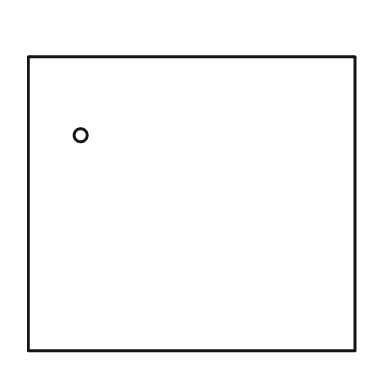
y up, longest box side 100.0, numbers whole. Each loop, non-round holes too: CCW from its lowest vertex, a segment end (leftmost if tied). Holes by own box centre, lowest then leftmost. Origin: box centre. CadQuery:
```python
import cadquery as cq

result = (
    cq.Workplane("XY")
    .moveTo(-50.0, -45.0)
    .lineTo(50.0, -45.0)
    .lineTo(50.0, 45.0)
    .lineTo(-50.0, 45.0)
    .close()
    .moveTo(-34.0, 21.0)
    .circle(2.0)
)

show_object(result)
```